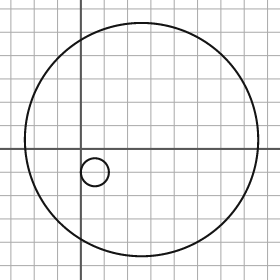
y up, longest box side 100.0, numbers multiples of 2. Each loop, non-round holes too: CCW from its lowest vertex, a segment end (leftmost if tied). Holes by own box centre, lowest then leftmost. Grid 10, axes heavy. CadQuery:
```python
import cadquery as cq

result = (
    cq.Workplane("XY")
    .moveTo(26.0, 4.0)
    .circle(50.0)
    .moveTo(6.0, -10.0)
    .circle(6.0)
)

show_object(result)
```